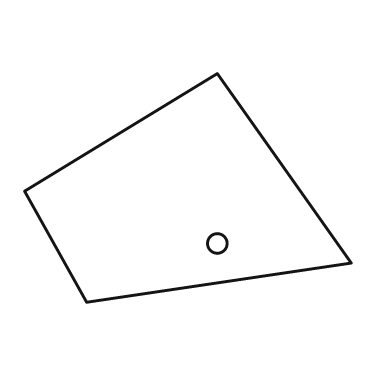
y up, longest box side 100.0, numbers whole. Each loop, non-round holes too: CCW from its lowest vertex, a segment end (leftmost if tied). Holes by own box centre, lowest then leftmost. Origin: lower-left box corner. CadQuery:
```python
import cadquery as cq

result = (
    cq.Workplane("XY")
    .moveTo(19.0, 0.0)
    .lineTo(100.0, 12.0)
    .lineTo(59.0, 70.0)
    .lineTo(0.0, 34.0)
    .close()
    .moveTo(59.0, 18.0)
    .circle(3.0)
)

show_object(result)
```